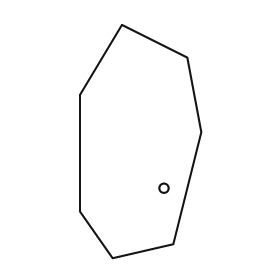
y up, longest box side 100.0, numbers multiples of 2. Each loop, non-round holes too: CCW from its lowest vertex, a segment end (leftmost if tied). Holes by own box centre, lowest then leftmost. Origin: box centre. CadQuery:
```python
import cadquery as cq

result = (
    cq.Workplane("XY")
    .moveTo(-12.0, -50.0)
    .lineTo(14.0, -44.0)
    .lineTo(26.0, 4.0)
    .lineTo(20.0, 36.0)
    .lineTo(-8.0, 50.0)
    .lineTo(-26.0, 20.0)
    .lineTo(-26.0, -30.0)
    .close()
    .moveTo(10.0, -20.0)
    .circle(2.0)
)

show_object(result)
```